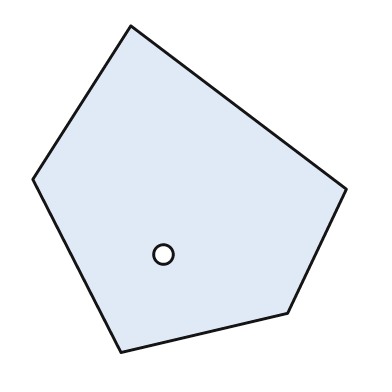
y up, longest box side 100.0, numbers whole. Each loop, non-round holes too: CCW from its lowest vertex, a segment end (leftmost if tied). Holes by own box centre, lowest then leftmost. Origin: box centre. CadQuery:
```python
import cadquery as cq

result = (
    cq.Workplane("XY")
    .moveTo(-21.0, -50.0)
    .lineTo(30.0, -38.0)
    .lineTo(48.0, 0.0)
    .lineTo(-18.0, 50.0)
    .lineTo(-48.0, 3.0)
    .close()
    .moveTo(-8.0, -20.0)
    .circle(3.0)
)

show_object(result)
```